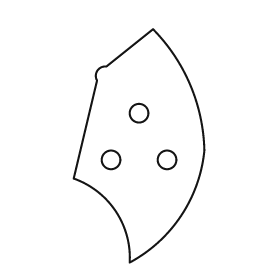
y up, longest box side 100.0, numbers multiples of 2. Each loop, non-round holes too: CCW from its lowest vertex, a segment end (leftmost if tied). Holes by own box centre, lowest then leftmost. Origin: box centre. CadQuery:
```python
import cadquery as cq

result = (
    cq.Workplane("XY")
    .moveTo(-4.0, -50.0)
    .threePointArc((18.0, -30.0), (28.0, -2.0))
    .threePointArc((22.0, 26.0), (6.0, 50.0))
    .lineTo(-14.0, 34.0)
    .threePointArc((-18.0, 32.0), (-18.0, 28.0))
    .lineTo(-28.0, -14.0)
    .threePointArc((-10.0, -28.0), (-4.0, -50.0))
    .close()
    .moveTo(-12.0, -6.0)
    .circle(4.0)
    .moveTo(12.0, -6.0)
    .circle(4.0)
    .moveTo(0.0, 14.0)
    .circle(4.0)
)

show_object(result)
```